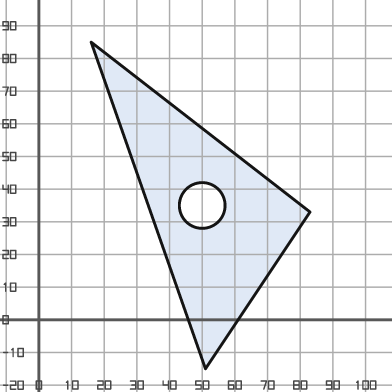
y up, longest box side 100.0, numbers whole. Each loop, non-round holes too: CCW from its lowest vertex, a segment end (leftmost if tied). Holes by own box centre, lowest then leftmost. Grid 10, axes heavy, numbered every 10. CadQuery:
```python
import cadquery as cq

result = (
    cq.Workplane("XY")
    .moveTo(51.0, -15.0)
    .lineTo(83.0, 33.0)
    .lineTo(16.0, 85.0)
    .close()
    .moveTo(50.0, 35.0)
    .circle(7.0)
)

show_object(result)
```